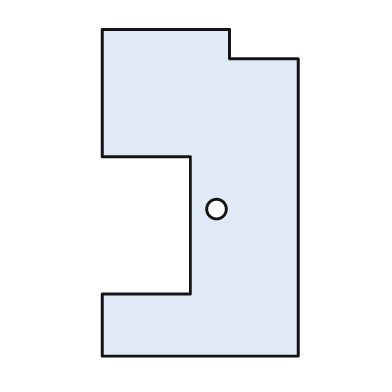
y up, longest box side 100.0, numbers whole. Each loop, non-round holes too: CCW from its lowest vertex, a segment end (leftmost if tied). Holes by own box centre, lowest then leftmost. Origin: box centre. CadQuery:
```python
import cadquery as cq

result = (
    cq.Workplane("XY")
    .moveTo(-30.0, -50.0)
    .lineTo(30.0, -50.0)
    .lineTo(30.0, 41.0)
    .lineTo(9.0, 41.0)
    .lineTo(9.0, 50.0)
    .lineTo(-30.0, 50.0)
    .lineTo(-30.0, 11.0)
    .lineTo(-3.0, 11.0)
    .lineTo(-3.0, -31.0)
    .lineTo(-30.0, -31.0)
    .close()
    .moveTo(5.0, -5.0)
    .circle(3.0)
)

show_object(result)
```